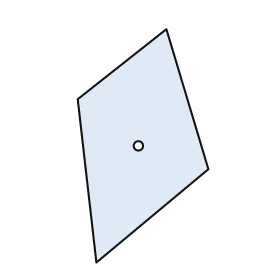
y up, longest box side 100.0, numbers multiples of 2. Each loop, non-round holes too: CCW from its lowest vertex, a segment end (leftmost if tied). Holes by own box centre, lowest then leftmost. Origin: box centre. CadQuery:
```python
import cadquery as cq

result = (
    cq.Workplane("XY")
    .moveTo(-20.0, -50.0)
    .lineTo(28.0, -10.0)
    .lineTo(10.0, 50.0)
    .lineTo(-28.0, 20.0)
    .close()
    .moveTo(-2.0, 0.0)
    .circle(2.0)
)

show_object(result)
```